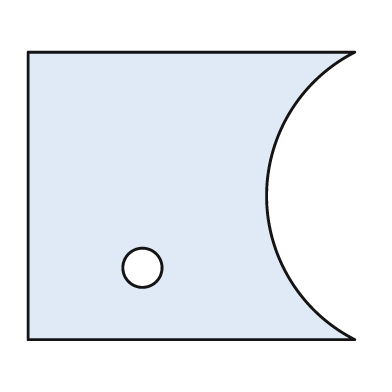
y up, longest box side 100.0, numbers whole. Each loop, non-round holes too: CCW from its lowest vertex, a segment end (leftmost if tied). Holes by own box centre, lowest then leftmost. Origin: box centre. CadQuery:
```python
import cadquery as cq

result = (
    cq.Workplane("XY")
    .moveTo(-50.0, -44.0)
    .lineTo(50.0, -44.0)
    .threePointArc((23.0, 0.0), (50.0, 44.0))
    .lineTo(-50.0, 44.0)
    .close()
    .moveTo(-15.0, -22.0)
    .circle(6.0)
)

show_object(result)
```